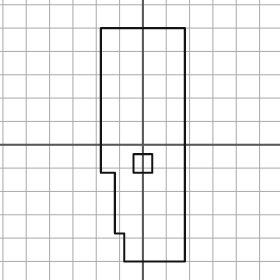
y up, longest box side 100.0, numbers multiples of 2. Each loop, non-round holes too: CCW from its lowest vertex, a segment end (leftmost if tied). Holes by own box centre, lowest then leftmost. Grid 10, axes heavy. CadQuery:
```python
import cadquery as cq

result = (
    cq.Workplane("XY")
    .moveTo(-8.0, -50.0)
    .lineTo(18.0, -50.0)
    .lineTo(18.0, 50.0)
    .lineTo(-18.0, 50.0)
    .lineTo(-18.0, -12.0)
    .lineTo(-12.0, -12.0)
    .lineTo(-12.0, -38.0)
    .lineTo(-8.0, -38.0)
    .close()
    .moveTo(-4.0, -12.0)
    .lineTo(4.0, -12.0)
    .lineTo(4.0, -4.0)
    .lineTo(-4.0, -4.0)
    .close()
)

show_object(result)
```